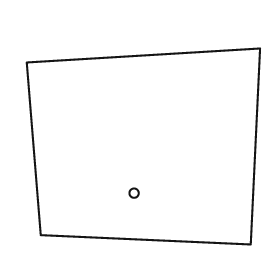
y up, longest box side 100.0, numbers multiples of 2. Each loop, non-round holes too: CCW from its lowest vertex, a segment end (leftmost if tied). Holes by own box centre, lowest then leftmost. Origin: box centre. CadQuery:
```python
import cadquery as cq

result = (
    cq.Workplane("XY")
    .moveTo(46.0, -42.0)
    .lineTo(50.0, 42.0)
    .lineTo(-50.0, 36.0)
    .lineTo(-44.0, -38.0)
    .close()
    .moveTo(-4.0, -20.0)
    .circle(2.0)
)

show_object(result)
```